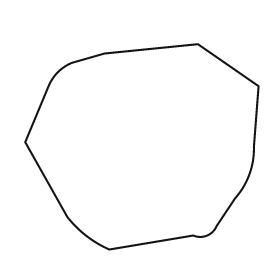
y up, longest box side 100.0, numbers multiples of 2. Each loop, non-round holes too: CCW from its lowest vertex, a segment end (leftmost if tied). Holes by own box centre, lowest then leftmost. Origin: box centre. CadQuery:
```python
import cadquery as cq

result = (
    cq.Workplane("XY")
    .moveTo(-14.0, -44.0)
    .lineTo(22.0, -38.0)
    .threePointArc((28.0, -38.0), (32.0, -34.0))
    .lineTo(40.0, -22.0)
    .threePointArc((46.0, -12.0), (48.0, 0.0))
    .lineTo(50.0, 26.0)
    .lineTo(24.0, 44.0)
    .lineTo(-16.0, 40.0)
    .lineTo(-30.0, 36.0)
    .threePointArc((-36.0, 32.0), (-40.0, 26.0))
    .lineTo(-50.0, 2.0)
    .lineTo(-32.0, -30.0)
    .threePointArc((-24.0, -38.0), (-14.0, -44.0))
    .close()
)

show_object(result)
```